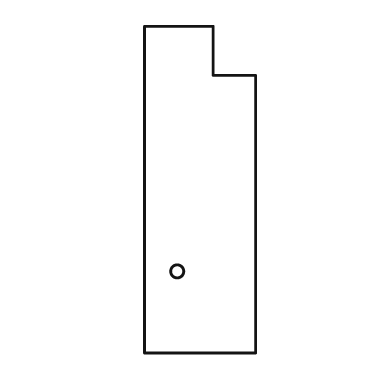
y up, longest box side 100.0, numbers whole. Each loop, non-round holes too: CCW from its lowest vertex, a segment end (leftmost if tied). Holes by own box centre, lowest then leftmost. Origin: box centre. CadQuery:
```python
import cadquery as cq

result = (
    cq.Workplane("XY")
    .moveTo(-17.0, -50.0)
    .lineTo(17.0, -50.0)
    .lineTo(17.0, 35.0)
    .lineTo(4.0, 35.0)
    .lineTo(4.0, 50.0)
    .lineTo(-17.0, 50.0)
    .close()
    .moveTo(-7.0, -25.0)
    .circle(2.0)
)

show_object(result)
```